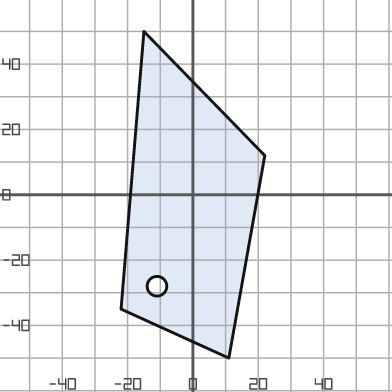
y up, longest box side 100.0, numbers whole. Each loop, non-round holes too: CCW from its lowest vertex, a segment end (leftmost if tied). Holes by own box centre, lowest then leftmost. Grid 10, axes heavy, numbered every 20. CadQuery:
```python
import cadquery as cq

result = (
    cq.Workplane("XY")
    .moveTo(11.0, -50.0)
    .lineTo(22.0, 12.0)
    .lineTo(-15.0, 50.0)
    .lineTo(-22.0, -35.0)
    .close()
    .moveTo(-11.0, -28.0)
    .circle(3.0)
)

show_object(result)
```